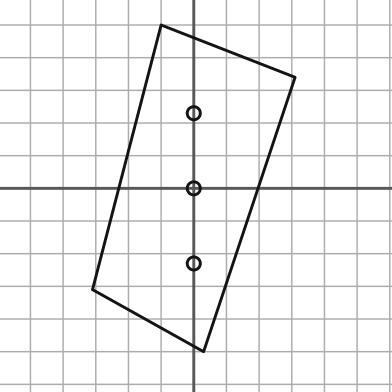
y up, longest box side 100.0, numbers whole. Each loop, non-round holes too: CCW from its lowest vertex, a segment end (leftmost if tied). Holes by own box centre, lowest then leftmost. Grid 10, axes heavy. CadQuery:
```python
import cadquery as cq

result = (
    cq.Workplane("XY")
    .moveTo(3.0, -50.0)
    .lineTo(31.0, 34.0)
    .lineTo(-10.0, 50.0)
    .lineTo(-31.0, -31.0)
    .close()
    .moveTo(0.0, -23.0)
    .circle(2.0)
    .moveTo(0.0, 0.0)
    .circle(2.0)
    .moveTo(0.0, 23.0)
    .circle(2.0)
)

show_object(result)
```